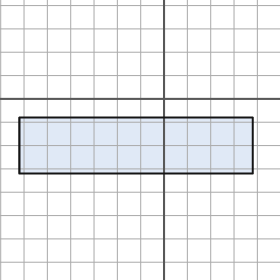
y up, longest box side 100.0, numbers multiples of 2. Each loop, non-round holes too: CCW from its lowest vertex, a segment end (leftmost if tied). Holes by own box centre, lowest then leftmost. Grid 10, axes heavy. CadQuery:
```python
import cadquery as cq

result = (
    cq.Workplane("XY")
    .moveTo(-62.0, -32.0)
    .lineTo(38.0, -32.0)
    .lineTo(38.0, -8.0)
    .lineTo(-62.0, -8.0)
    .close()
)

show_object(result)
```